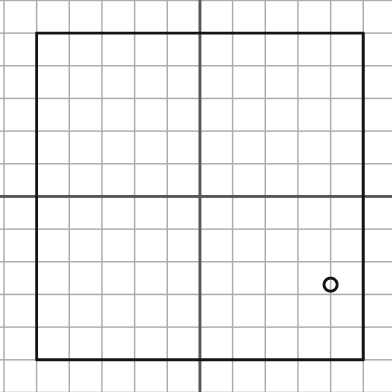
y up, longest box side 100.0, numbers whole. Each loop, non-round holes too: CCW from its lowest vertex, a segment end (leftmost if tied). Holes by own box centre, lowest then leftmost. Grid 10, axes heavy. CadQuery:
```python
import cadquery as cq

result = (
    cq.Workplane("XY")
    .moveTo(-50.0, -50.0)
    .lineTo(50.0, -50.0)
    .lineTo(50.0, 50.0)
    .lineTo(-50.0, 50.0)
    .close()
    .moveTo(40.0, -27.0)
    .circle(2.0)
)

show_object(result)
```